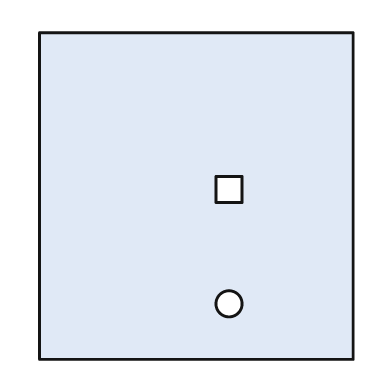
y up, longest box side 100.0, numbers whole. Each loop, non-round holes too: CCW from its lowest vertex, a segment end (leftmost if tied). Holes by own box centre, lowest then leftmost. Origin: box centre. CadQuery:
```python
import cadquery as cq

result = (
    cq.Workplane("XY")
    .moveTo(-48.0, -50.0)
    .lineTo(48.0, -50.0)
    .lineTo(48.0, 50.0)
    .lineTo(-48.0, 50.0)
    .close()
    .moveTo(10.0, -33.0)
    .circle(4.0)
    .moveTo(6.0, -2.0)
    .lineTo(14.0, -2.0)
    .lineTo(14.0, 6.0)
    .lineTo(6.0, 6.0)
    .close()
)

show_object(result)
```